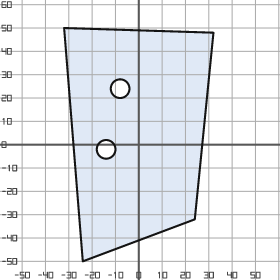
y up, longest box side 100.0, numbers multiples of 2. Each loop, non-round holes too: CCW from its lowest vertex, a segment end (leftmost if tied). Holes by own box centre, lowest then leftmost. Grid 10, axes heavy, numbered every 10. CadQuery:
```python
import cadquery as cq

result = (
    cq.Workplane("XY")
    .moveTo(-24.0, -50.0)
    .lineTo(24.0, -32.0)
    .lineTo(32.0, 48.0)
    .lineTo(-32.0, 50.0)
    .close()
    .moveTo(-14.0, -2.0)
    .circle(4.0)
    .moveTo(-8.0, 24.0)
    .circle(4.0)
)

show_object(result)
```